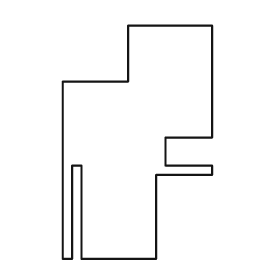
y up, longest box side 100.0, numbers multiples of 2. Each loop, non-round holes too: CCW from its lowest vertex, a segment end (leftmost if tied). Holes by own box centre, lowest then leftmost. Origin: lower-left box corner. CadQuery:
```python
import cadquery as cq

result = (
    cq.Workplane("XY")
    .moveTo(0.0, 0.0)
    .lineTo(4.0, 0.0)
    .lineTo(4.0, 40.0)
    .lineTo(8.0, 40.0)
    .lineTo(8.0, 0.0)
    .lineTo(40.0, 0.0)
    .lineTo(40.0, 36.0)
    .lineTo(64.0, 36.0)
    .lineTo(64.0, 40.0)
    .lineTo(44.0, 40.0)
    .lineTo(44.0, 52.0)
    .lineTo(64.0, 52.0)
    .lineTo(64.0, 100.0)
    .lineTo(28.0, 100.0)
    .lineTo(28.0, 76.0)
    .lineTo(0.0, 76.0)
    .close()
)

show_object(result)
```